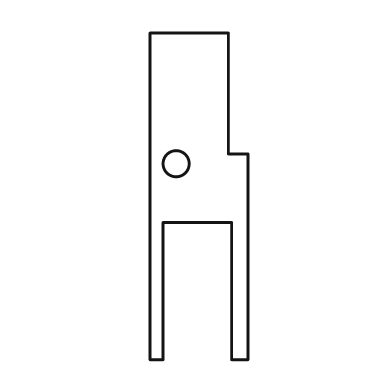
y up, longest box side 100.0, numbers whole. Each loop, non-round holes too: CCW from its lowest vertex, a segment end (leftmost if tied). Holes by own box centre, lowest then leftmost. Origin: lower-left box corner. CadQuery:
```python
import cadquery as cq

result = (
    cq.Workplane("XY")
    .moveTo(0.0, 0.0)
    .lineTo(4.0, 0.0)
    .lineTo(4.0, 42.0)
    .lineTo(25.0, 42.0)
    .lineTo(25.0, 0.0)
    .lineTo(30.0, 0.0)
    .lineTo(30.0, 63.0)
    .lineTo(24.0, 63.0)
    .lineTo(24.0, 100.0)
    .lineTo(0.0, 100.0)
    .close()
    .moveTo(8.0, 60.0)
    .circle(4.0)
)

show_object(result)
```